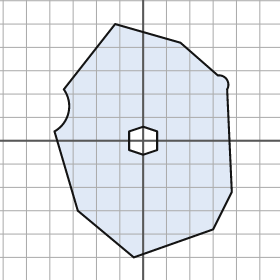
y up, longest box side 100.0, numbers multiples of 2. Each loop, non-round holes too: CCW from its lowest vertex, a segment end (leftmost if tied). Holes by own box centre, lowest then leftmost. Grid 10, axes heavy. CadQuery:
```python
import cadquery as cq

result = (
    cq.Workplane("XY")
    .moveTo(-4.0, -50.0)
    .lineTo(30.0, -38.0)
    .lineTo(38.0, -22.0)
    .lineTo(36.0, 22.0)
    .threePointArc((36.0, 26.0), (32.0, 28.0))
    .lineTo(16.0, 42.0)
    .lineTo(-12.0, 50.0)
    .lineTo(-34.0, 22.0)
    .threePointArc((-32.0, 12.0), (-38.0, 4.0))
    .lineTo(-28.0, -30.0)
    .close()
    .moveTo(0.0, -6.0)
    .lineTo(6.0, -4.0)
    .lineTo(6.0, 4.0)
    .lineTo(0.0, 6.0)
    .lineTo(-6.0, 4.0)
    .lineTo(-6.0, -4.0)
    .close()
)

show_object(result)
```